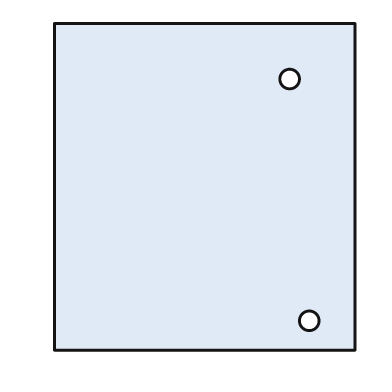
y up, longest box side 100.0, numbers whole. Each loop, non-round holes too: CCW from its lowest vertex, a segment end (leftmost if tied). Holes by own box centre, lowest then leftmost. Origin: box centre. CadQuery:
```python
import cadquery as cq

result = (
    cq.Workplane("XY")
    .moveTo(-46.0, -50.0)
    .lineTo(46.0, -50.0)
    .lineTo(46.0, 50.0)
    .lineTo(-46.0, 50.0)
    .close()
    .moveTo(32.0, -41.0)
    .circle(3.0)
    .moveTo(26.0, 33.0)
    .circle(3.0)
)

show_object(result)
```